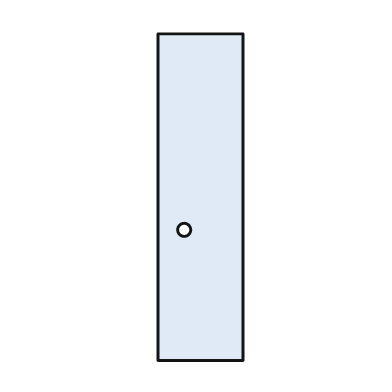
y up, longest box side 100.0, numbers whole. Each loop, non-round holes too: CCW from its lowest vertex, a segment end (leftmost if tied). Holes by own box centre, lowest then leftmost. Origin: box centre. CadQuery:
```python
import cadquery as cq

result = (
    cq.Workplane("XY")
    .moveTo(-13.0, -50.0)
    .lineTo(13.0, -50.0)
    .lineTo(13.0, 50.0)
    .lineTo(-13.0, 50.0)
    .close()
    .moveTo(-5.0, -10.0)
    .circle(2.0)
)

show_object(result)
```